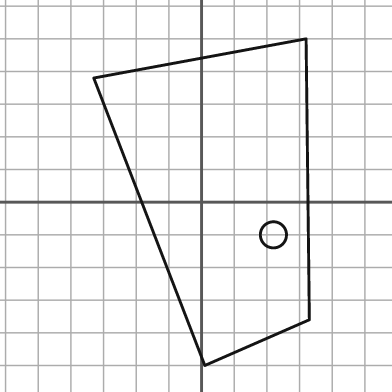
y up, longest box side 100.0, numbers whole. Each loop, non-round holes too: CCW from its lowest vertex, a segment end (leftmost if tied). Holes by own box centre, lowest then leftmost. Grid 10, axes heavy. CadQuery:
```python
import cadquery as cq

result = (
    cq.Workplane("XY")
    .moveTo(1.0, -50.0)
    .lineTo(33.0, -36.0)
    .lineTo(32.0, 50.0)
    .lineTo(-33.0, 38.0)
    .close()
    .moveTo(22.0, -10.0)
    .circle(4.0)
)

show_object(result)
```